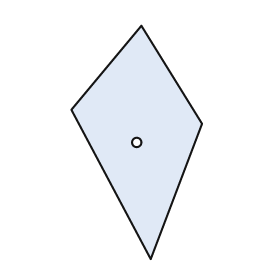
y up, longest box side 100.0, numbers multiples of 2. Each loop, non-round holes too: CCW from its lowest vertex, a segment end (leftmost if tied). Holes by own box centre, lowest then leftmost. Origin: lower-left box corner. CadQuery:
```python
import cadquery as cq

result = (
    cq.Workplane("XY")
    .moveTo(34.0, 0.0)
    .lineTo(56.0, 58.0)
    .lineTo(30.0, 100.0)
    .lineTo(0.0, 64.0)
    .close()
    .moveTo(28.0, 50.0)
    .circle(2.0)
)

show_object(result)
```